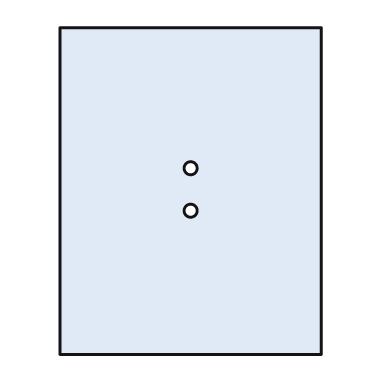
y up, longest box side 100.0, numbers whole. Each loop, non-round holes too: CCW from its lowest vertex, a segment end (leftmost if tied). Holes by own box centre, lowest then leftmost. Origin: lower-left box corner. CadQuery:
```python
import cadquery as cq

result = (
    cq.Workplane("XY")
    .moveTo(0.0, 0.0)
    .lineTo(80.0, 0.0)
    .lineTo(80.0, 100.0)
    .lineTo(0.0, 100.0)
    .close()
    .moveTo(40.0, 44.0)
    .circle(2.0)
    .moveTo(40.0, 57.0)
    .circle(2.0)
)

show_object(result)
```